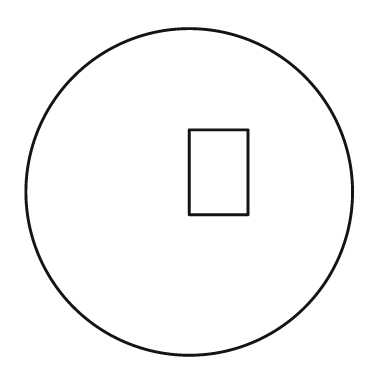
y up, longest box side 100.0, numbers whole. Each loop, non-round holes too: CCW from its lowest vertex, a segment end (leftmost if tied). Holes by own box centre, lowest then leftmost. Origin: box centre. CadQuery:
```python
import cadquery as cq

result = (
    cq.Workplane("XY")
    .moveTo(0.0, 0.0)
    .circle(50.0)
    .moveTo(0.0, -7.0)
    .lineTo(18.0, -7.0)
    .lineTo(18.0, 19.0)
    .lineTo(0.0, 19.0)
    .close()
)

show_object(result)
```